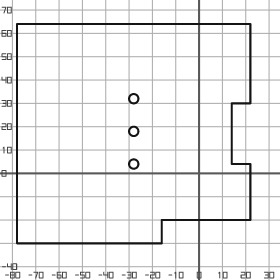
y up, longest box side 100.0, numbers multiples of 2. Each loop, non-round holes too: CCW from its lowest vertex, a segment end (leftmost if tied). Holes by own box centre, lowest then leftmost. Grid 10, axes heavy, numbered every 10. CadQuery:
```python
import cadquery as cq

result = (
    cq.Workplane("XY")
    .moveTo(-78.0, -30.0)
    .lineTo(-16.0, -30.0)
    .lineTo(-16.0, -20.0)
    .lineTo(22.0, -20.0)
    .lineTo(22.0, 4.0)
    .lineTo(14.0, 4.0)
    .lineTo(14.0, 30.0)
    .lineTo(22.0, 30.0)
    .lineTo(22.0, 64.0)
    .lineTo(-78.0, 64.0)
    .close()
    .moveTo(-28.0, 4.0)
    .circle(2.0)
    .moveTo(-28.0, 18.0)
    .circle(2.0)
    .moveTo(-28.0, 32.0)
    .circle(2.0)
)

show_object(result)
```